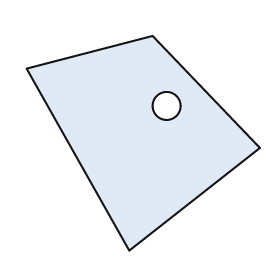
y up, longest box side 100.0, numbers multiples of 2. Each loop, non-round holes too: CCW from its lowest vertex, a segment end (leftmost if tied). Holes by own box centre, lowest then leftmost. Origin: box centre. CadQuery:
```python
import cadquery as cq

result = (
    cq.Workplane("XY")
    .moveTo(-6.0, -46.0)
    .lineTo(50.0, -2.0)
    .lineTo(4.0, 46.0)
    .lineTo(-50.0, 32.0)
    .close()
    .moveTo(10.0, 16.0)
    .circle(6.0)
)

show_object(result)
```